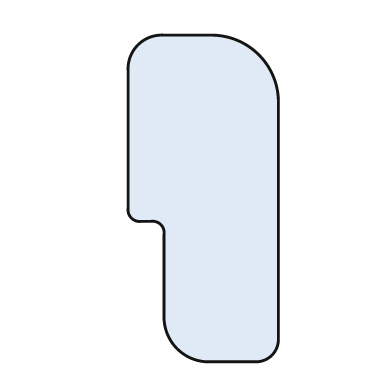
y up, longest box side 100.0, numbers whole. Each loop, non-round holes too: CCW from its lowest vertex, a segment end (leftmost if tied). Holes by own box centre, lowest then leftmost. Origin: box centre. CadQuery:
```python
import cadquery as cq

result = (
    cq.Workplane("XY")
    .moveTo(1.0, -50.0)
    .lineTo(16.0, -50.0)
    .threePointArc((21.0, -48.0), (23.0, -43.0))
    .lineTo(23.0, 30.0)
    .threePointArc((17.0, 44.0), (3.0, 50.0))
    .lineTo(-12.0, 50.0)
    .threePointArc((-20.0, 47.0), (-23.0, 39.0))
    .lineTo(-23.0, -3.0)
    .threePointArc((-22.0, -6.0), (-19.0, -7.0))
    .lineTo(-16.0, -7.0)
    .threePointArc((-13.0, -8.0), (-12.0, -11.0))
    .lineTo(-12.0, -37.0)
    .threePointArc((-8.0, -46.0), (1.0, -50.0))
    .close()
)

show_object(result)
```